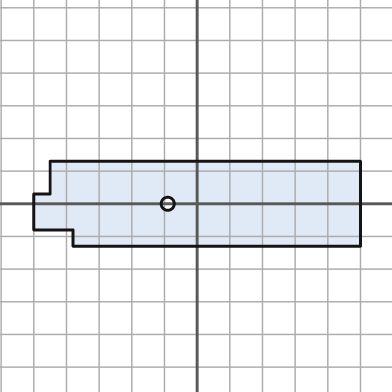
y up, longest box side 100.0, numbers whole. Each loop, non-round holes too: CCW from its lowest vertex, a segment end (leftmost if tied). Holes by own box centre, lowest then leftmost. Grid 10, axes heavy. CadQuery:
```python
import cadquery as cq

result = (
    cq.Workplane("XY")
    .moveTo(-38.0, -13.0)
    .lineTo(50.0, -13.0)
    .lineTo(50.0, 13.0)
    .lineTo(-45.0, 13.0)
    .lineTo(-45.0, 3.0)
    .lineTo(-50.0, 3.0)
    .lineTo(-50.0, -8.0)
    .lineTo(-38.0, -8.0)
    .close()
    .moveTo(-9.0, 0.0)
    .circle(2.0)
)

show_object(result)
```